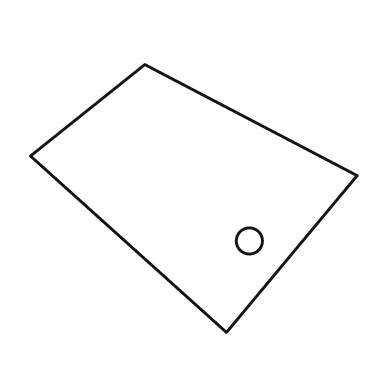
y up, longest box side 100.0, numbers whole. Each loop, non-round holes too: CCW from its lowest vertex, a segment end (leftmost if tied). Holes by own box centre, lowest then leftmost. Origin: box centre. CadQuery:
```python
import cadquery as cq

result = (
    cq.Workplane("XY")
    .moveTo(10.0, -41.0)
    .lineTo(50.0, 7.0)
    .lineTo(-15.0, 41.0)
    .lineTo(-50.0, 13.0)
    .close()
    .moveTo(17.0, -13.0)
    .circle(4.0)
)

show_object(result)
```